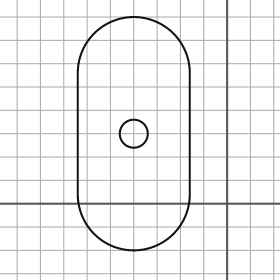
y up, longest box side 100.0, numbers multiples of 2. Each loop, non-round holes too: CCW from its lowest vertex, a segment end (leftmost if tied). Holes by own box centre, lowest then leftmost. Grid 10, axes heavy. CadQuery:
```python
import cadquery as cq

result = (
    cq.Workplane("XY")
    .moveTo(-64.0, 4.0)
    .threePointArc((-40.0, -20.0), (-16.0, 4.0))
    .lineTo(-16.0, 56.0)
    .threePointArc((-40.0, 80.0), (-64.0, 56.0))
    .close()
    .moveTo(-40.0, 30.0)
    .circle(6.0)
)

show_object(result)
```